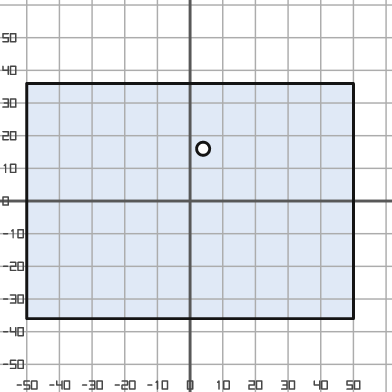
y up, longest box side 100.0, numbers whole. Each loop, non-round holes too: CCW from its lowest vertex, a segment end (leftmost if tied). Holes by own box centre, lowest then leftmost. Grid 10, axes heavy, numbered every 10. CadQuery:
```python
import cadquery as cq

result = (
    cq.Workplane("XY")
    .moveTo(-50.0, -36.0)
    .lineTo(50.0, -36.0)
    .lineTo(50.0, 36.0)
    .lineTo(-50.0, 36.0)
    .close()
    .moveTo(4.0, 16.0)
    .circle(2.0)
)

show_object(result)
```